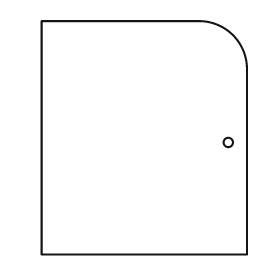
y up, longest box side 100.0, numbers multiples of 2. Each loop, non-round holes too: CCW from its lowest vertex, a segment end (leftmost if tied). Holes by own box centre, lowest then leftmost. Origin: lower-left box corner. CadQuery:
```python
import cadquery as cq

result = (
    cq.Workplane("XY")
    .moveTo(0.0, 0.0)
    .lineTo(88.0, 0.0)
    .lineTo(88.0, 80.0)
    .threePointArc((82.0, 94.0), (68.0, 100.0))
    .lineTo(0.0, 100.0)
    .close()
    .moveTo(80.0, 48.0)
    .circle(2.0)
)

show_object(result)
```